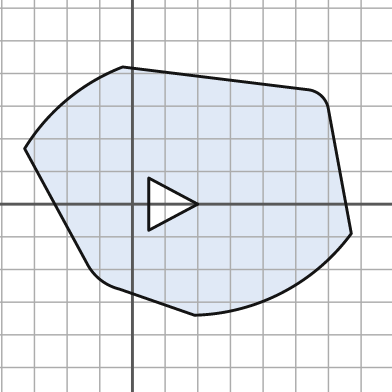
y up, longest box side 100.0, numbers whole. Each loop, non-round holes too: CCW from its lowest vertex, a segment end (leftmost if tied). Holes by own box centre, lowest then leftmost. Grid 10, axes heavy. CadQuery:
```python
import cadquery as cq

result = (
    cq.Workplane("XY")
    .moveTo(19.0, -34.0)
    .threePointArc((46.0, -27.0), (67.0, -9.0))
    .lineTo(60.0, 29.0)
    .threePointArc((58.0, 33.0), (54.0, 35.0))
    .lineTo(-3.0, 42.0)
    .threePointArc((-20.0, 32.0), (-33.0, 17.0))
    .lineTo(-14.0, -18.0)
    .threePointArc((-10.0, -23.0), (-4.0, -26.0))
    .close()
    .moveTo(5.0, -8.0)
    .lineTo(20.0, 0.0)
    .lineTo(5.0, 8.0)
    .close()
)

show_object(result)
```